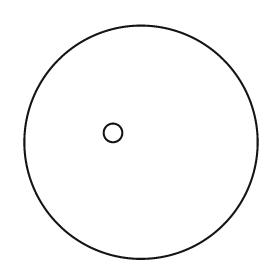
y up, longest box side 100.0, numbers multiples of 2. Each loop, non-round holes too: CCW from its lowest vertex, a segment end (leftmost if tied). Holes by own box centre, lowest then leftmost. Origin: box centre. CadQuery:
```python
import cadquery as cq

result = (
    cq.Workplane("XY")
    .moveTo(0.0, 0.0)
    .circle(50.0)
    .moveTo(-12.0, 4.0)
    .circle(4.0)
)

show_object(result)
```